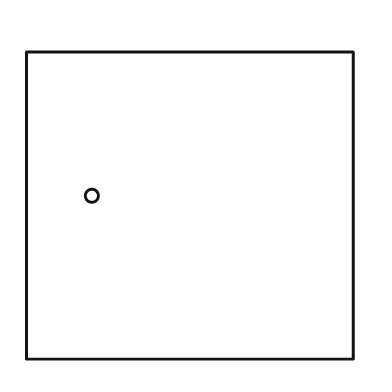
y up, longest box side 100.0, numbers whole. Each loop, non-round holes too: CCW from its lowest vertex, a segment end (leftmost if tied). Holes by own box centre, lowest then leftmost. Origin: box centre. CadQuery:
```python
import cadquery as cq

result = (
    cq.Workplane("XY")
    .moveTo(-50.0, -47.0)
    .lineTo(50.0, -47.0)
    .lineTo(50.0, 47.0)
    .lineTo(-50.0, 47.0)
    .close()
    .moveTo(-30.0, 3.0)
    .circle(2.0)
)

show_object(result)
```